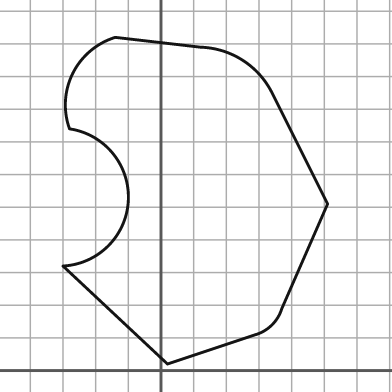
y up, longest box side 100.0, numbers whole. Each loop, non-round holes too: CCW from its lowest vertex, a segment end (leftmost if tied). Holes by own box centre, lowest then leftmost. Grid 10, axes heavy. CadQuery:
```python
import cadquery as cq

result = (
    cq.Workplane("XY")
    .moveTo(2.0, 2.0)
    .lineTo(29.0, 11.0)
    .threePointArc((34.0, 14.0), (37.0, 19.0))
    .lineTo(51.0, 51.0)
    .lineTo(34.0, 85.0)
    .threePointArc((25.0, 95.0), (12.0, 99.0))
    .lineTo(-14.0, 102.0)
    .threePointArc((-27.0, 91.0), (-28.0, 74.0))
    .threePointArc((-10.0, 52.0), (-30.0, 32.0))
    .close()
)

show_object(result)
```